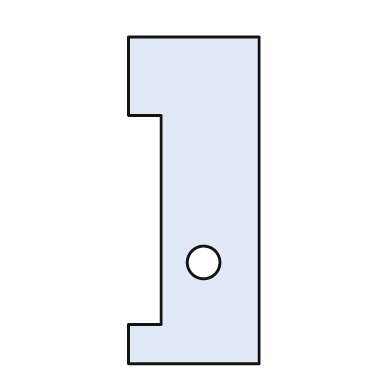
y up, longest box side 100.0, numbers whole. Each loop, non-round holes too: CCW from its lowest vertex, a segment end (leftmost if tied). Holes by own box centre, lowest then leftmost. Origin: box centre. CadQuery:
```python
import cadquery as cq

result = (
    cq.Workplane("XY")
    .moveTo(-20.0, -50.0)
    .lineTo(20.0, -50.0)
    .lineTo(20.0, 50.0)
    .lineTo(-20.0, 50.0)
    .lineTo(-20.0, 26.0)
    .lineTo(-10.0, 26.0)
    .lineTo(-10.0, -38.0)
    .lineTo(-20.0, -38.0)
    .close()
    .moveTo(3.0, -19.0)
    .circle(5.0)
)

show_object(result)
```